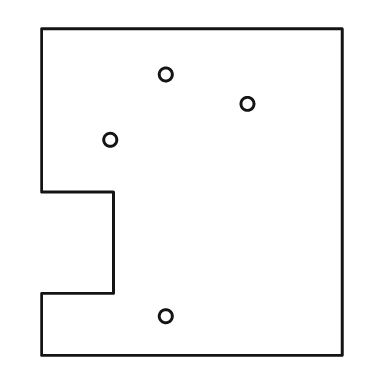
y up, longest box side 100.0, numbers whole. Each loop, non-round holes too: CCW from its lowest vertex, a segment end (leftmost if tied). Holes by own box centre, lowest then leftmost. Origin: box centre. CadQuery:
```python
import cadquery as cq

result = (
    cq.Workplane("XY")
    .moveTo(-46.0, -50.0)
    .lineTo(46.0, -50.0)
    .lineTo(46.0, 50.0)
    .lineTo(-46.0, 50.0)
    .lineTo(-46.0, 0.0)
    .lineTo(-24.0, 0.0)
    .lineTo(-24.0, -31.0)
    .lineTo(-46.0, -31.0)
    .close()
    .moveTo(-8.0, -38.0)
    .circle(2.0)
    .moveTo(-25.0, 16.0)
    .circle(2.0)
    .moveTo(17.0, 27.0)
    .circle(2.0)
    .moveTo(-8.0, 36.0)
    .circle(2.0)
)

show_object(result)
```